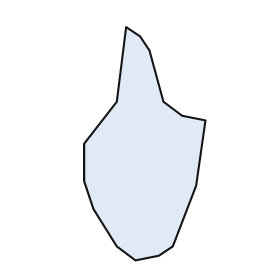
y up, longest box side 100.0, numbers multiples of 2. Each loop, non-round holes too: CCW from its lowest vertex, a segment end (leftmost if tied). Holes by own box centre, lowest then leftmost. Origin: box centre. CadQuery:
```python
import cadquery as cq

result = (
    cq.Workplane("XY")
    .moveTo(-4.0, -50.0)
    .lineTo(6.0, -48.0)
    .lineTo(12.0, -44.0)
    .lineTo(22.0, -18.0)
    .lineTo(26.0, 10.0)
    .lineTo(16.0, 12.0)
    .lineTo(8.0, 18.0)
    .lineTo(2.0, 40.0)
    .lineTo(-2.0, 46.0)
    .lineTo(-8.0, 50.0)
    .lineTo(-12.0, 18.0)
    .lineTo(-26.0, 0.0)
    .lineTo(-26.0, -16.0)
    .lineTo(-22.0, -28.0)
    .lineTo(-12.0, -44.0)
    .close()
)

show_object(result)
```